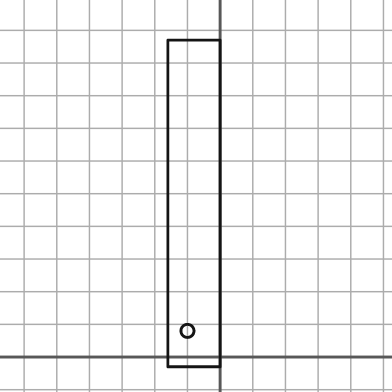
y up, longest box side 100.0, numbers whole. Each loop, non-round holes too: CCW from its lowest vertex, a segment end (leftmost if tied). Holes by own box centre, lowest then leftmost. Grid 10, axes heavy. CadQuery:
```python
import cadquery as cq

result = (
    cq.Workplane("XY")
    .moveTo(-16.0, -3.0)
    .lineTo(0.0, -3.0)
    .lineTo(0.0, 97.0)
    .lineTo(-16.0, 97.0)
    .close()
    .moveTo(-10.0, 8.0)
    .circle(2.0)
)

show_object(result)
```